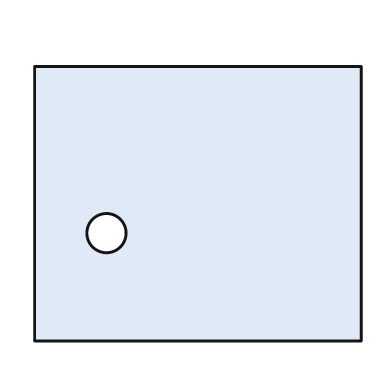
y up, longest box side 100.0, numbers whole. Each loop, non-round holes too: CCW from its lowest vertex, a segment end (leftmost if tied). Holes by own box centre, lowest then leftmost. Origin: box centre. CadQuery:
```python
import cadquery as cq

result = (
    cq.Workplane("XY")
    .moveTo(-50.0, -42.0)
    .lineTo(50.0, -42.0)
    .lineTo(50.0, 42.0)
    .lineTo(-50.0, 42.0)
    .close()
    .moveTo(-28.0, -9.0)
    .circle(6.0)
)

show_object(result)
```